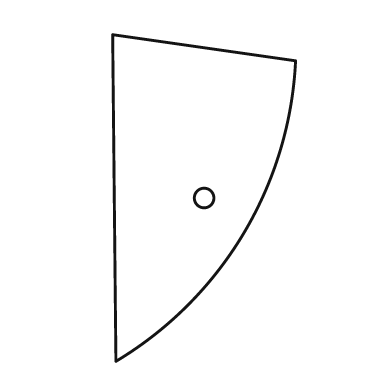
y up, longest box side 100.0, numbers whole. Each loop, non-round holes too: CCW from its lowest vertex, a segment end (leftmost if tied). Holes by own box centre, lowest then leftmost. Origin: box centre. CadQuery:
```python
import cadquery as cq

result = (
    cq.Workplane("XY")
    .moveTo(-27.0, -50.0)
    .threePointArc((12.0, -11.0), (28.0, 42.0))
    .lineTo(-28.0, 50.0)
    .close()
    .moveTo(0.0, 0.0)
    .circle(3.0)
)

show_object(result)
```